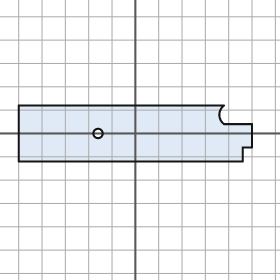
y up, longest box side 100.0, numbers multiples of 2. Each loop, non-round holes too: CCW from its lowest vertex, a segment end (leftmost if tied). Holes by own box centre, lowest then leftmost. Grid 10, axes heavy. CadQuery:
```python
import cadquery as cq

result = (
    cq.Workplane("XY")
    .moveTo(-50.0, -12.0)
    .lineTo(46.0, -12.0)
    .lineTo(46.0, -6.0)
    .lineTo(50.0, -6.0)
    .lineTo(50.0, 4.0)
    .lineTo(38.0, 4.0)
    .threePointArc((36.0, 8.0), (38.0, 12.0))
    .lineTo(-50.0, 12.0)
    .close()
    .moveTo(-16.0, 0.0)
    .circle(2.0)
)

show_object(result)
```